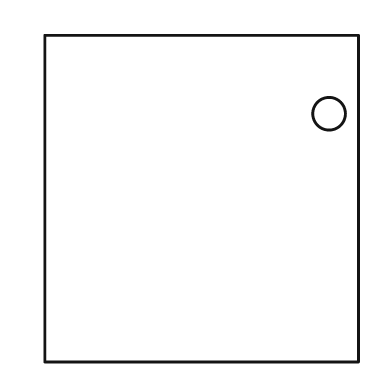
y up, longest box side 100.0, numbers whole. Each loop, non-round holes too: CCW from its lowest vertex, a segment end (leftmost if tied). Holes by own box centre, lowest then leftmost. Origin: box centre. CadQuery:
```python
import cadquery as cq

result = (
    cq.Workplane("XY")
    .moveTo(-48.0, -50.0)
    .lineTo(48.0, -50.0)
    .lineTo(48.0, 50.0)
    .lineTo(-48.0, 50.0)
    .close()
    .moveTo(39.0, 26.0)
    .circle(5.0)
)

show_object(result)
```